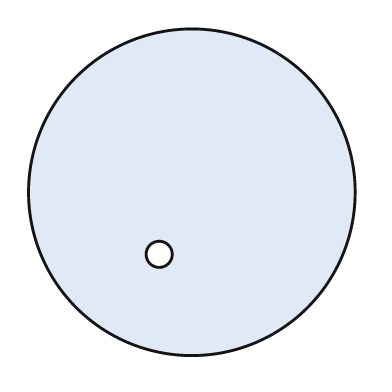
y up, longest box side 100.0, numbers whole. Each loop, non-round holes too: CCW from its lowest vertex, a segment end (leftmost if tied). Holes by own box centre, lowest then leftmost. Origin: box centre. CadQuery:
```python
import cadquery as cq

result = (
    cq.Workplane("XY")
    .moveTo(0.0, 0.0)
    .circle(50.0)
    .moveTo(-10.0, -19.0)
    .circle(4.0)
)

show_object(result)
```